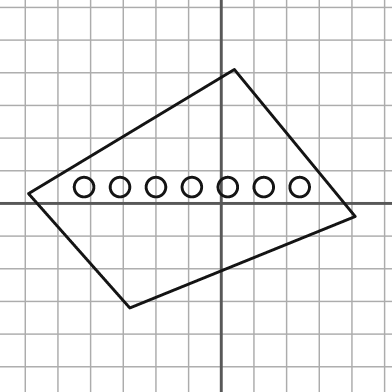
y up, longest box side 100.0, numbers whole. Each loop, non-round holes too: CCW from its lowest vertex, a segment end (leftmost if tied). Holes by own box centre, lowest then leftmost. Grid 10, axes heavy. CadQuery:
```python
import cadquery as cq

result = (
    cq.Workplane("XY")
    .moveTo(-28.0, -32.0)
    .lineTo(41.0, -4.0)
    .lineTo(4.0, 41.0)
    .lineTo(-59.0, 3.0)
    .close()
    .moveTo(-42.0, 5.0)
    .circle(3.0)
    .moveTo(-31.0, 5.0)
    .circle(3.0)
    .moveTo(-20.0, 5.0)
    .circle(3.0)
    .moveTo(-9.0, 5.0)
    .circle(3.0)
    .moveTo(2.0, 5.0)
    .circle(3.0)
    .moveTo(13.0, 5.0)
    .circle(3.0)
    .moveTo(24.0, 5.0)
    .circle(3.0)
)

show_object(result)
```